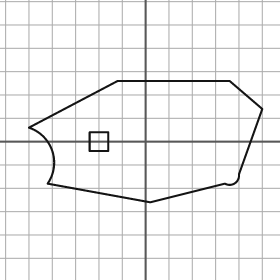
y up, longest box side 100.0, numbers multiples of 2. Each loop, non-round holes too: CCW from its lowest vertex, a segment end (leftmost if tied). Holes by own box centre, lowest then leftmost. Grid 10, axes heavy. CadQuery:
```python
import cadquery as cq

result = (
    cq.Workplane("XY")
    .moveTo(2.0, -26.0)
    .lineTo(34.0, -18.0)
    .threePointArc((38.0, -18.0), (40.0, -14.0))
    .lineTo(50.0, 14.0)
    .lineTo(36.0, 26.0)
    .lineTo(-12.0, 26.0)
    .lineTo(-50.0, 6.0)
    .threePointArc((-40.0, -4.0), (-42.0, -18.0))
    .close()
    .moveTo(-24.0, -4.0)
    .lineTo(-16.0, -4.0)
    .lineTo(-16.0, 4.0)
    .lineTo(-24.0, 4.0)
    .close()
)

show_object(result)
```